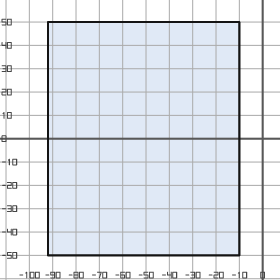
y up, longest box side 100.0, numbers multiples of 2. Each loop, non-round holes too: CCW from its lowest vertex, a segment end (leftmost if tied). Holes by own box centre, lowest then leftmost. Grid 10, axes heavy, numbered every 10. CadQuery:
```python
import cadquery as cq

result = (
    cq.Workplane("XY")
    .moveTo(-92.0, -50.0)
    .lineTo(-10.0, -50.0)
    .lineTo(-10.0, 50.0)
    .lineTo(-92.0, 50.0)
    .close()
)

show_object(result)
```